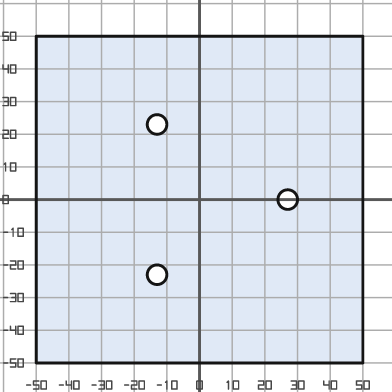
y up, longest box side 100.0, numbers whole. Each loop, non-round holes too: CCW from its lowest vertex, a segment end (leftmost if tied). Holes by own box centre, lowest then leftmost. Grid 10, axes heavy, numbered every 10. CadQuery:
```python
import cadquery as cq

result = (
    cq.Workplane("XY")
    .moveTo(-50.0, -50.0)
    .lineTo(50.0, -50.0)
    .lineTo(50.0, 50.0)
    .lineTo(-50.0, 50.0)
    .close()
    .moveTo(-13.0, -23.0)
    .circle(3.0)
    .moveTo(27.0, 0.0)
    .circle(3.0)
    .moveTo(-13.0, 23.0)
    .circle(3.0)
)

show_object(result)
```